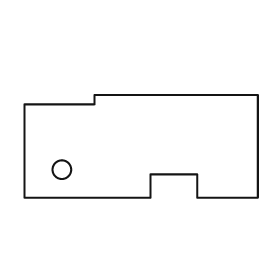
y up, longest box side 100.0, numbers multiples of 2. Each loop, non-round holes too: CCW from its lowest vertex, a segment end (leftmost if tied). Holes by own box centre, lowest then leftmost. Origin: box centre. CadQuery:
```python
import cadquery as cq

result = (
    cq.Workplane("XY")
    .moveTo(-50.0, -22.0)
    .lineTo(4.0, -22.0)
    .lineTo(4.0, -12.0)
    .lineTo(24.0, -12.0)
    .lineTo(24.0, -22.0)
    .lineTo(50.0, -22.0)
    .lineTo(50.0, 22.0)
    .lineTo(-20.0, 22.0)
    .lineTo(-20.0, 18.0)
    .lineTo(-50.0, 18.0)
    .close()
    .moveTo(-34.0, -10.0)
    .circle(4.0)
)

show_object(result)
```